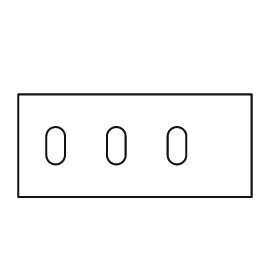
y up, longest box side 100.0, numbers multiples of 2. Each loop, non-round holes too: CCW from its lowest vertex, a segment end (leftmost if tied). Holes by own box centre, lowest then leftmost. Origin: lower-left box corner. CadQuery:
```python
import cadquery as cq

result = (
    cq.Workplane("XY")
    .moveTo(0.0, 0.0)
    .lineTo(100.0, 0.0)
    .lineTo(100.0, 44.0)
    .lineTo(0.0, 44.0)
    .close()
    .moveTo(12.0, 18.0)
    .threePointArc((16.0, 14.0), (20.0, 18.0))
    .lineTo(20.0, 26.0)
    .threePointArc((16.0, 30.0), (12.0, 26.0))
    .close()
    .moveTo(38.0, 18.0)
    .threePointArc((42.0, 14.0), (46.0, 18.0))
    .lineTo(46.0, 26.0)
    .threePointArc((42.0, 30.0), (38.0, 26.0))
    .close()
    .moveTo(64.0, 18.0)
    .threePointArc((68.0, 14.0), (72.0, 18.0))
    .lineTo(72.0, 26.0)
    .threePointArc((68.0, 30.0), (64.0, 26.0))
    .close()
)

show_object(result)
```